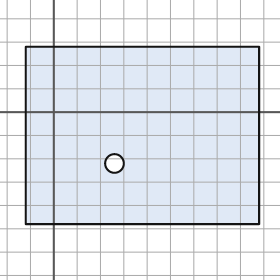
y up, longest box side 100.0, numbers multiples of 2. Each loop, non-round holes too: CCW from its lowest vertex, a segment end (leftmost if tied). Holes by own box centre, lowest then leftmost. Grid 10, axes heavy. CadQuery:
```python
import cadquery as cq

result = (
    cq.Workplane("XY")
    .moveTo(-12.0, -48.0)
    .lineTo(88.0, -48.0)
    .lineTo(88.0, 28.0)
    .lineTo(-12.0, 28.0)
    .close()
    .moveTo(26.0, -22.0)
    .circle(4.0)
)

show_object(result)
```